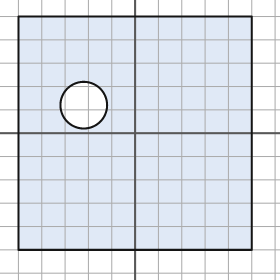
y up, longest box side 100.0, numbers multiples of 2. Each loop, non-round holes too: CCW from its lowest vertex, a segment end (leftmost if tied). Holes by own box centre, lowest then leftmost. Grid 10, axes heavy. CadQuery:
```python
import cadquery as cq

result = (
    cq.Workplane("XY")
    .moveTo(-50.0, -50.0)
    .lineTo(50.0, -50.0)
    .lineTo(50.0, 50.0)
    .lineTo(-50.0, 50.0)
    .close()
    .moveTo(-22.0, 12.0)
    .circle(10.0)
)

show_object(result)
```